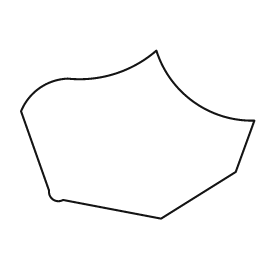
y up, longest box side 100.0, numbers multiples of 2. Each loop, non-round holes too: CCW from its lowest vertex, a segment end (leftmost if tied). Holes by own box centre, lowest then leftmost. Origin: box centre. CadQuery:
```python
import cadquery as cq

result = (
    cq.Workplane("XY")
    .moveTo(10.0, -36.0)
    .lineTo(42.0, -16.0)
    .lineTo(50.0, 6.0)
    .threePointArc((24.0, 14.0), (8.0, 36.0))
    .threePointArc((-10.0, 26.0), (-30.0, 24.0))
    .threePointArc((-42.0, 20.0), (-50.0, 10.0))
    .lineTo(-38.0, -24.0)
    .threePointArc((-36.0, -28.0), (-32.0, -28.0))
    .close()
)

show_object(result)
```